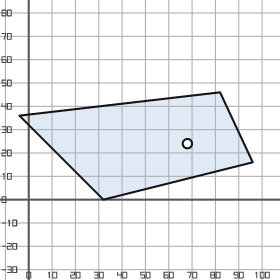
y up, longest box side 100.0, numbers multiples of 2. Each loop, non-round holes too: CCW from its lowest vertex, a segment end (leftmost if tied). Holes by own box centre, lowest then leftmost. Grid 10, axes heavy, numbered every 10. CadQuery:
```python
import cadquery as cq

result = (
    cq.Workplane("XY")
    .moveTo(32.0, 0.0)
    .lineTo(96.0, 16.0)
    .lineTo(82.0, 46.0)
    .lineTo(-4.0, 36.0)
    .close()
    .moveTo(68.0, 24.0)
    .circle(2.0)
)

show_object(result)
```